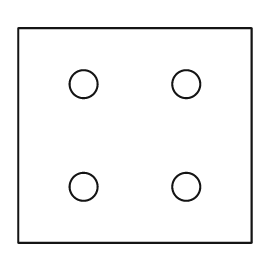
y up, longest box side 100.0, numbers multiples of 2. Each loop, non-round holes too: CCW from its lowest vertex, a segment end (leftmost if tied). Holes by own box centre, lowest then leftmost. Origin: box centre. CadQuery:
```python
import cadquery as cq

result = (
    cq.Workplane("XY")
    .moveTo(-50.0, -46.0)
    .lineTo(50.0, -46.0)
    .lineTo(50.0, 46.0)
    .lineTo(-50.0, 46.0)
    .close()
    .moveTo(-22.0, -22.0)
    .circle(6.0)
    .moveTo(22.0, -22.0)
    .circle(6.0)
    .moveTo(-22.0, 22.0)
    .circle(6.0)
    .moveTo(22.0, 22.0)
    .circle(6.0)
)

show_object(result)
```